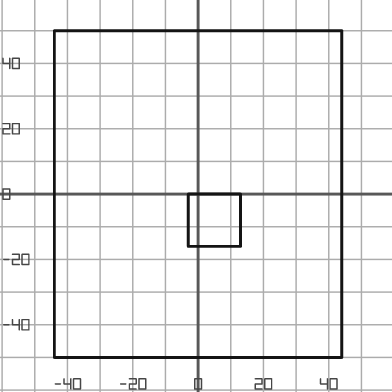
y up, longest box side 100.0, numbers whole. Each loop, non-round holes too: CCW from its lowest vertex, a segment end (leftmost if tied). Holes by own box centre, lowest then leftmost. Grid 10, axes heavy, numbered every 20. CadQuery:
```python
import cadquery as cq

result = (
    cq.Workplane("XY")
    .moveTo(-44.0, -50.0)
    .lineTo(44.0, -50.0)
    .lineTo(44.0, 50.0)
    .lineTo(-44.0, 50.0)
    .close()
    .moveTo(-3.0, -16.0)
    .lineTo(13.0, -16.0)
    .lineTo(13.0, 0.0)
    .lineTo(-3.0, 0.0)
    .close()
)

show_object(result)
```